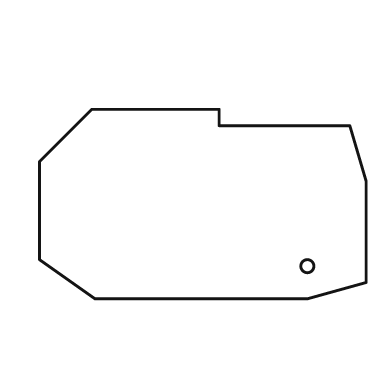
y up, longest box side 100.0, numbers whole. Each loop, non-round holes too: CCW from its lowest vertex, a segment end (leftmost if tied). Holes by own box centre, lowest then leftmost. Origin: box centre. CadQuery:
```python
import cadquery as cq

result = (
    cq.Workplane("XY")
    .moveTo(-33.0, -29.0)
    .lineTo(32.0, -29.0)
    .lineTo(50.0, -24.0)
    .lineTo(50.0, 7.0)
    .lineTo(45.0, 24.0)
    .lineTo(5.0, 24.0)
    .lineTo(5.0, 29.0)
    .lineTo(-34.0, 29.0)
    .lineTo(-50.0, 13.0)
    .lineTo(-50.0, -17.0)
    .close()
    .moveTo(32.0, -19.0)
    .circle(2.0)
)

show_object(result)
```